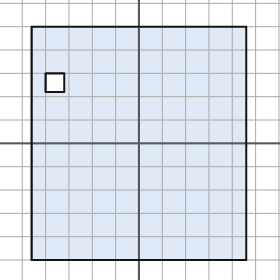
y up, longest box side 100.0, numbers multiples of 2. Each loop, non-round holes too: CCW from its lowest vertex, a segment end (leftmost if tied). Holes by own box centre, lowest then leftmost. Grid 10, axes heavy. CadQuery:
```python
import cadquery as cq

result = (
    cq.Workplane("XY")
    .moveTo(-46.0, -50.0)
    .lineTo(46.0, -50.0)
    .lineTo(46.0, 50.0)
    .lineTo(-46.0, 50.0)
    .close()
    .moveTo(-40.0, 22.0)
    .lineTo(-32.0, 22.0)
    .lineTo(-32.0, 30.0)
    .lineTo(-40.0, 30.0)
    .close()
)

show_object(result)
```